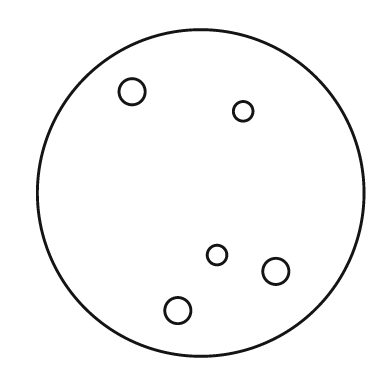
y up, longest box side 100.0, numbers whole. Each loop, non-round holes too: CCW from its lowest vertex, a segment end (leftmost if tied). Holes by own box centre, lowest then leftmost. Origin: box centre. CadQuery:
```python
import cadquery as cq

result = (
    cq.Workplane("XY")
    .moveTo(0.0, 0.0)
    .circle(50.0)
    .moveTo(-7.0, -36.0)
    .circle(4.0)
    .moveTo(23.0, -24.0)
    .circle(4.0)
    .moveTo(5.0, -19.0)
    .circle(3.0)
    .moveTo(13.0, 25.0)
    .circle(3.0)
    .moveTo(-21.0, 31.0)
    .circle(4.0)
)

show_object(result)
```